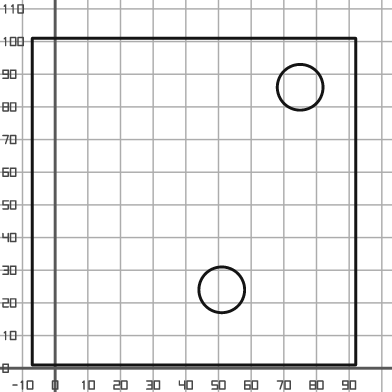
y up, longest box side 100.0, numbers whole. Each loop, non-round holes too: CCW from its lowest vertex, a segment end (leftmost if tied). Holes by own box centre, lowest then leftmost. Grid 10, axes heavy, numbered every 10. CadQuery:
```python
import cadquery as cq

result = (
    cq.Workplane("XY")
    .moveTo(-7.0, 1.0)
    .lineTo(92.0, 1.0)
    .lineTo(92.0, 101.0)
    .lineTo(-7.0, 101.0)
    .close()
    .moveTo(51.0, 24.0)
    .circle(7.0)
    .moveTo(75.0, 86.0)
    .circle(7.0)
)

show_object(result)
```